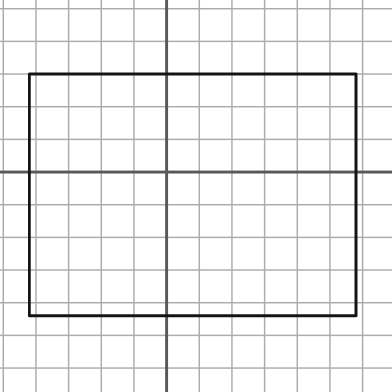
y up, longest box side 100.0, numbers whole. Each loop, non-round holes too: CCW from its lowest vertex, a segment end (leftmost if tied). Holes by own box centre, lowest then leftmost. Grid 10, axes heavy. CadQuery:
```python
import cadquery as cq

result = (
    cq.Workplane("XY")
    .moveTo(-42.0, -44.0)
    .lineTo(58.0, -44.0)
    .lineTo(58.0, 30.0)
    .lineTo(-42.0, 30.0)
    .close()
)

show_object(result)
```